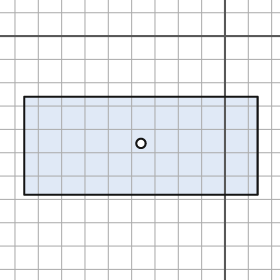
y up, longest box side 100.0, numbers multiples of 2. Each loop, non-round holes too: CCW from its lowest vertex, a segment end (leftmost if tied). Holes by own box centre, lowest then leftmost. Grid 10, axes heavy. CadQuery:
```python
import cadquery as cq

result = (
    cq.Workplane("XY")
    .moveTo(-86.0, -68.0)
    .lineTo(14.0, -68.0)
    .lineTo(14.0, -26.0)
    .lineTo(-86.0, -26.0)
    .close()
    .moveTo(-36.0, -46.0)
    .circle(2.0)
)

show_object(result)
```